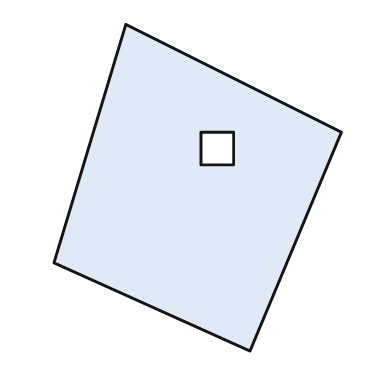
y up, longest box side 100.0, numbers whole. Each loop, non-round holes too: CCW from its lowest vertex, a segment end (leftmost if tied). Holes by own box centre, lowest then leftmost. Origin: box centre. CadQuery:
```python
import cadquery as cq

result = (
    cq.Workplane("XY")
    .moveTo(16.0, -50.0)
    .lineTo(44.0, 17.0)
    .lineTo(-22.0, 50.0)
    .lineTo(-44.0, -23.0)
    .close()
    .moveTo(1.0, 7.0)
    .lineTo(11.0, 7.0)
    .lineTo(11.0, 17.0)
    .lineTo(1.0, 17.0)
    .close()
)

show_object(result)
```